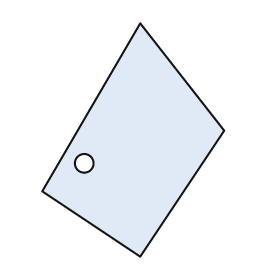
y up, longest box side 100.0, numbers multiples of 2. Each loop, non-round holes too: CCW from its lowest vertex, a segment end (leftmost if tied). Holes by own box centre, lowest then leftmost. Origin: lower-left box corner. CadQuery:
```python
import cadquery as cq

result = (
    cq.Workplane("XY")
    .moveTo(42.0, 0.0)
    .lineTo(78.0, 54.0)
    .lineTo(42.0, 100.0)
    .lineTo(0.0, 28.0)
    .close()
    .moveTo(18.0, 40.0)
    .circle(4.0)
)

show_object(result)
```